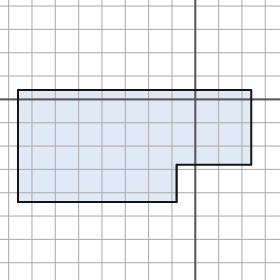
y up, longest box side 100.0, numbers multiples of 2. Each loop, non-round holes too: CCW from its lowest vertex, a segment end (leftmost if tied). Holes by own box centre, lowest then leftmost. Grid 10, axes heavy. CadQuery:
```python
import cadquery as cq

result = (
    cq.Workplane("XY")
    .moveTo(-76.0, -44.0)
    .lineTo(-8.0, -44.0)
    .lineTo(-8.0, -28.0)
    .lineTo(24.0, -28.0)
    .lineTo(24.0, 4.0)
    .lineTo(-76.0, 4.0)
    .close()
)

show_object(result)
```